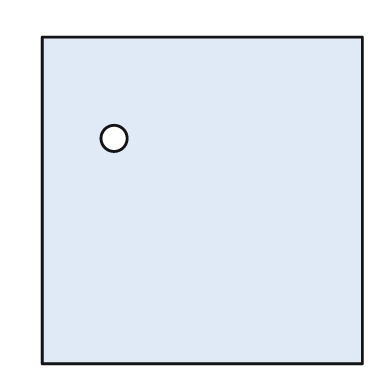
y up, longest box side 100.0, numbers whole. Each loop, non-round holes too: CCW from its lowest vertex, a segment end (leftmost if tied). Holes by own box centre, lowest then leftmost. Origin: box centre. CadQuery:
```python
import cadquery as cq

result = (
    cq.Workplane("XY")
    .moveTo(-49.0, -50.0)
    .lineTo(49.0, -50.0)
    .lineTo(49.0, 50.0)
    .lineTo(-49.0, 50.0)
    .close()
    .moveTo(-27.0, 19.0)
    .circle(4.0)
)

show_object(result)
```